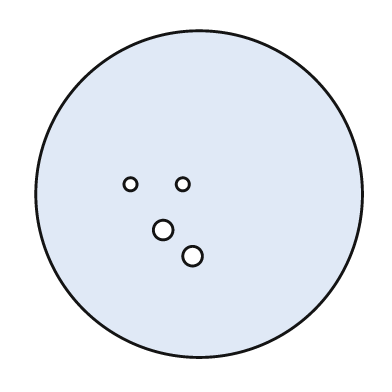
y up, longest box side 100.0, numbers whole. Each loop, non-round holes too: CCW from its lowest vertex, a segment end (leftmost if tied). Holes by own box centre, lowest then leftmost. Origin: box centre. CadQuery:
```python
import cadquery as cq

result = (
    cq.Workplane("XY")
    .moveTo(0.0, 0.0)
    .circle(50.0)
    .moveTo(-2.0, -19.0)
    .circle(3.0)
    .moveTo(-11.0, -11.0)
    .circle(3.0)
    .moveTo(-21.0, 3.0)
    .circle(2.0)
    .moveTo(-5.0, 3.0)
    .circle(2.0)
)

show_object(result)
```